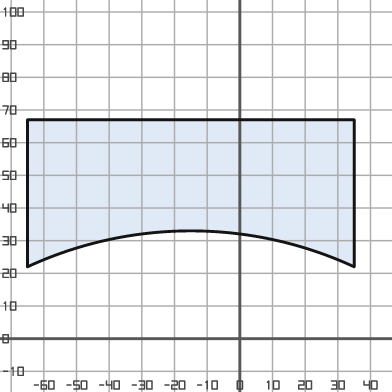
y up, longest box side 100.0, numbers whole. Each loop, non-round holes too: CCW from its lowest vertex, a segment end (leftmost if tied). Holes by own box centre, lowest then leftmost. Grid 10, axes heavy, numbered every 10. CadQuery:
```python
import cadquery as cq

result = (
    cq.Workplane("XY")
    .moveTo(-65.0, 22.0)
    .threePointArc((-15.0, 33.0), (35.0, 22.0))
    .lineTo(35.0, 67.0)
    .lineTo(-65.0, 67.0)
    .close()
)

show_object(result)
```